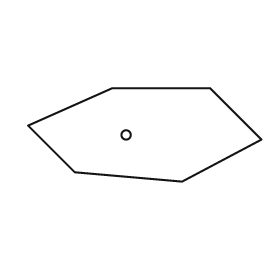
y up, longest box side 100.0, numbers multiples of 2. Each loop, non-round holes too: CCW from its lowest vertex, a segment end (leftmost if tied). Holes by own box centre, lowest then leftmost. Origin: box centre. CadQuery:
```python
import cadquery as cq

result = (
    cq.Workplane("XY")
    .moveTo(16.0, -20.0)
    .lineTo(50.0, -2.0)
    .lineTo(28.0, 20.0)
    .lineTo(-14.0, 20.0)
    .lineTo(-50.0, 4.0)
    .lineTo(-30.0, -16.0)
    .close()
    .moveTo(-8.0, 0.0)
    .circle(2.0)
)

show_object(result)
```